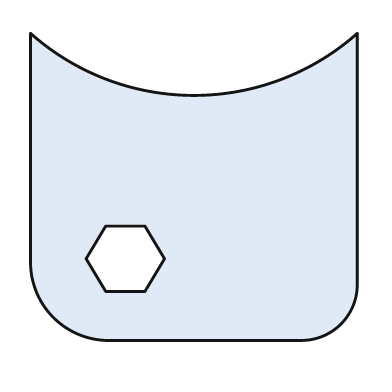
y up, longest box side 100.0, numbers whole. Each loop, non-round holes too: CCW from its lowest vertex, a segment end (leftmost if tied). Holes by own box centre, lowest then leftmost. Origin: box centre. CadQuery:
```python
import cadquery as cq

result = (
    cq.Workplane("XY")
    .moveTo(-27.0, -47.0)
    .lineTo(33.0, -47.0)
    .threePointArc((45.0, -42.0), (50.0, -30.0))
    .lineTo(50.0, 47.0)
    .threePointArc((0.0, 28.0), (-50.0, 47.0))
    .lineTo(-50.0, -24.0)
    .threePointArc((-43.0, -40.0), (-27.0, -47.0))
    .close()
    .moveTo(-27.0, -32.0)
    .lineTo(-15.0, -32.0)
    .lineTo(-9.0, -22.0)
    .lineTo(-15.0, -12.0)
    .lineTo(-27.0, -12.0)
    .lineTo(-33.0, -22.0)
    .close()
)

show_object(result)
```